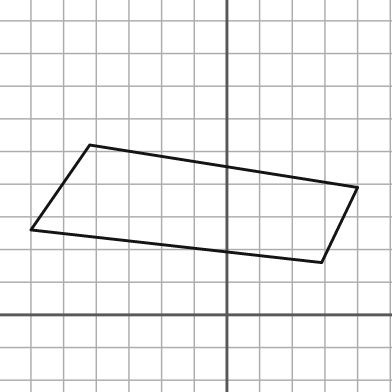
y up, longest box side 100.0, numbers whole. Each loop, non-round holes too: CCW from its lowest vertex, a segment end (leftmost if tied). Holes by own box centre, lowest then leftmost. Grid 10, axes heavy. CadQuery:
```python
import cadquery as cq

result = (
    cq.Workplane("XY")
    .moveTo(29.0, 16.0)
    .lineTo(40.0, 39.0)
    .lineTo(-42.0, 52.0)
    .lineTo(-60.0, 26.0)
    .close()
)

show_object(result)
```